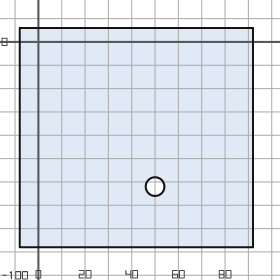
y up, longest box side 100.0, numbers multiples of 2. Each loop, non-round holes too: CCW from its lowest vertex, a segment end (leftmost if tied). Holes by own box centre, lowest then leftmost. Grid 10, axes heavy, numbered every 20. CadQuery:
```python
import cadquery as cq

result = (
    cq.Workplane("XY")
    .moveTo(-8.0, -88.0)
    .lineTo(92.0, -88.0)
    .lineTo(92.0, 6.0)
    .lineTo(-8.0, 6.0)
    .close()
    .moveTo(50.0, -62.0)
    .circle(4.0)
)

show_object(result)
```